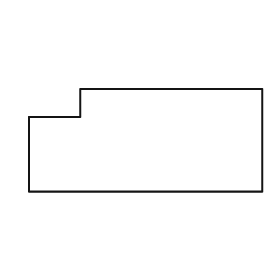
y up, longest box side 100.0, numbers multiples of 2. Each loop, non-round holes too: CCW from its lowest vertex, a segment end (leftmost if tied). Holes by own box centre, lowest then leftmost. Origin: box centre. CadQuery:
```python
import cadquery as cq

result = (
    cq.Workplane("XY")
    .moveTo(-50.0, -22.0)
    .lineTo(50.0, -22.0)
    .lineTo(50.0, 22.0)
    .lineTo(-28.0, 22.0)
    .lineTo(-28.0, 10.0)
    .lineTo(-50.0, 10.0)
    .close()
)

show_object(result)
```